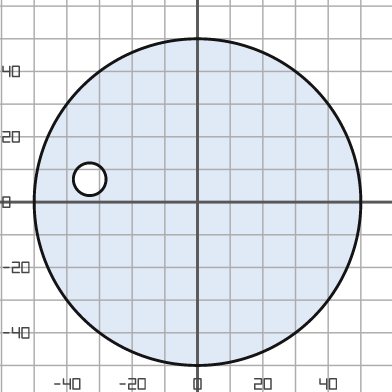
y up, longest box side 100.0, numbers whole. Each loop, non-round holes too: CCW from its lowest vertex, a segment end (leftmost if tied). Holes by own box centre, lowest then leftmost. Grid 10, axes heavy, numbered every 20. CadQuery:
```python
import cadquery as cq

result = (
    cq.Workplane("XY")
    .moveTo(0.0, 0.0)
    .circle(50.0)
    .moveTo(-33.0, 7.0)
    .circle(5.0)
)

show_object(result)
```